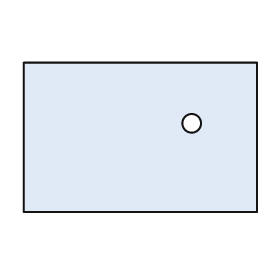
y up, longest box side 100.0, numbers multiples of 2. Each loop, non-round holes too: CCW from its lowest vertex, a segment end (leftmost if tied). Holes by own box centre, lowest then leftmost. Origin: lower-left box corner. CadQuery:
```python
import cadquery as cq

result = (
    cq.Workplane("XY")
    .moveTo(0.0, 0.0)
    .lineTo(100.0, 0.0)
    .lineTo(100.0, 64.0)
    .lineTo(0.0, 64.0)
    .close()
    .moveTo(72.0, 38.0)
    .circle(4.0)
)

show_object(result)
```